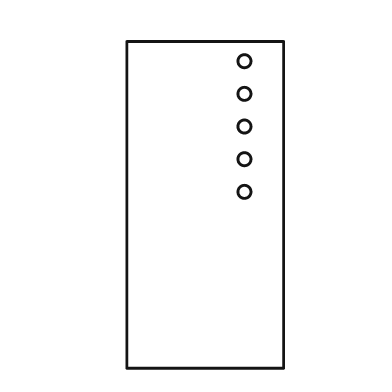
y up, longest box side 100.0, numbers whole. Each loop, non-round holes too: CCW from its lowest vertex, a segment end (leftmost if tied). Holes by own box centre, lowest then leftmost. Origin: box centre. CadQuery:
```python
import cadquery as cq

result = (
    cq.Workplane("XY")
    .moveTo(-24.0, -50.0)
    .lineTo(24.0, -50.0)
    .lineTo(24.0, 50.0)
    .lineTo(-24.0, 50.0)
    .close()
    .moveTo(12.0, 4.0)
    .circle(2.0)
    .moveTo(12.0, 14.0)
    .circle(2.0)
    .moveTo(12.0, 24.0)
    .circle(2.0)
    .moveTo(12.0, 34.0)
    .circle(2.0)
    .moveTo(12.0, 44.0)
    .circle(2.0)
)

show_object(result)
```